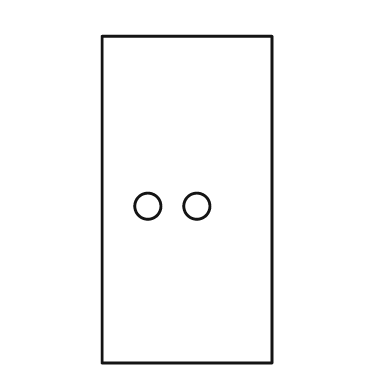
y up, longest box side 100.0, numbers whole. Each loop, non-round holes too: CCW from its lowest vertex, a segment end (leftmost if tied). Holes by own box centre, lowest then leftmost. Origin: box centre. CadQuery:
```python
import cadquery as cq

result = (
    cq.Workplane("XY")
    .moveTo(-26.0, -50.0)
    .lineTo(26.0, -50.0)
    .lineTo(26.0, 50.0)
    .lineTo(-26.0, 50.0)
    .close()
    .moveTo(-12.0, -2.0)
    .circle(4.0)
    .moveTo(3.0, -2.0)
    .circle(4.0)
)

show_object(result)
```